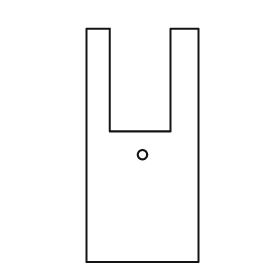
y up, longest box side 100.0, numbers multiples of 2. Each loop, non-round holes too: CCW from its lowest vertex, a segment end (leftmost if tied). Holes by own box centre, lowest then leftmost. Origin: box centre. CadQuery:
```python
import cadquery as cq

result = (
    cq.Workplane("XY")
    .moveTo(-24.0, -50.0)
    .lineTo(24.0, -50.0)
    .lineTo(24.0, 50.0)
    .lineTo(12.0, 50.0)
    .lineTo(12.0, 6.0)
    .lineTo(-14.0, 6.0)
    .lineTo(-14.0, 50.0)
    .lineTo(-24.0, 50.0)
    .close()
    .moveTo(0.0, -4.0)
    .circle(2.0)
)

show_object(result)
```